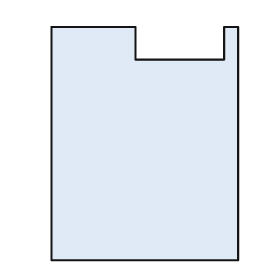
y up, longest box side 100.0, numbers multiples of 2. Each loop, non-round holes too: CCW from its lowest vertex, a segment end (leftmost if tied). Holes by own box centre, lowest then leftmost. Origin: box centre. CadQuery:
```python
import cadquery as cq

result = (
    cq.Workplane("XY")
    .moveTo(-40.0, -50.0)
    .lineTo(40.0, -50.0)
    .lineTo(40.0, 50.0)
    .lineTo(34.0, 50.0)
    .lineTo(34.0, 36.0)
    .lineTo(-4.0, 36.0)
    .lineTo(-4.0, 50.0)
    .lineTo(-40.0, 50.0)
    .close()
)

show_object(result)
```